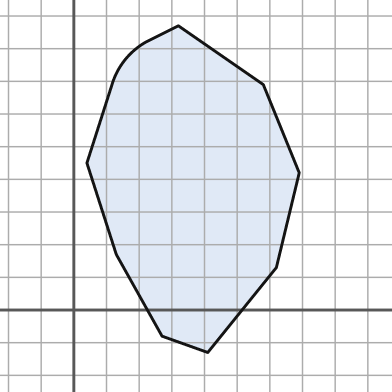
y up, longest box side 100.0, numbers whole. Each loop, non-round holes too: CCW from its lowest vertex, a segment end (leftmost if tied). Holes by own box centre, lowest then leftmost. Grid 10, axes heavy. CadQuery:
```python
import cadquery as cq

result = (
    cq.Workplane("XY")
    .moveTo(41.0, -13.0)
    .lineTo(62.0, 13.0)
    .lineTo(69.0, 42.0)
    .lineTo(58.0, 69.0)
    .lineTo(32.0, 87.0)
    .lineTo(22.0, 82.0)
    .threePointArc((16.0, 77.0), (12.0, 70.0))
    .lineTo(4.0, 45.0)
    .lineTo(13.0, 17.0)
    .lineTo(27.0, -8.0)
    .close()
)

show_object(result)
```